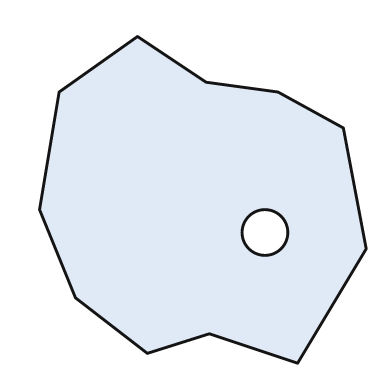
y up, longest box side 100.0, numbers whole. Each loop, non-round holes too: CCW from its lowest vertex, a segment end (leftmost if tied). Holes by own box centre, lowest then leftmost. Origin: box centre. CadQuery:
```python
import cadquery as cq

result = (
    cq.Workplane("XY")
    .moveTo(29.0, -50.0)
    .lineTo(50.0, -15.0)
    .lineTo(43.0, 22.0)
    .lineTo(23.0, 33.0)
    .lineTo(1.0, 36.0)
    .lineTo(-20.0, 50.0)
    .lineTo(-44.0, 33.0)
    .lineTo(-50.0, -3.0)
    .lineTo(-39.0, -30.0)
    .lineTo(-17.0, -47.0)
    .lineTo(2.0, -41.0)
    .close()
    .moveTo(19.0, -10.0)
    .circle(7.0)
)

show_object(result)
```